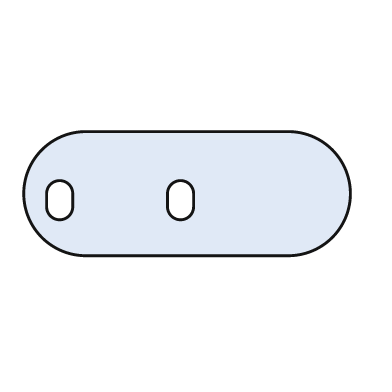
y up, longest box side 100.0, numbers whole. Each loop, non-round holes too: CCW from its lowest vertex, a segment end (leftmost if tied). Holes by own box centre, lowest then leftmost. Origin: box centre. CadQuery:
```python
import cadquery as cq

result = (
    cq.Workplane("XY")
    .moveTo(-31.0, -19.0)
    .lineTo(31.0, -19.0)
    .threePointArc((50.0, 0.0), (31.0, 19.0))
    .lineTo(-31.0, 19.0)
    .threePointArc((-50.0, 0.0), (-31.0, -19.0))
    .close()
    .moveTo(-43.0, -4.0)
    .threePointArc((-39.0, -8.0), (-35.0, -4.0))
    .lineTo(-35.0, 0.0)
    .threePointArc((-39.0, 4.0), (-43.0, 0.0))
    .close()
    .moveTo(-6.0, -4.0)
    .threePointArc((-2.0, -8.0), (2.0, -4.0))
    .lineTo(2.0, 0.0)
    .threePointArc((-2.0, 4.0), (-6.0, 0.0))
    .close()
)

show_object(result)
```